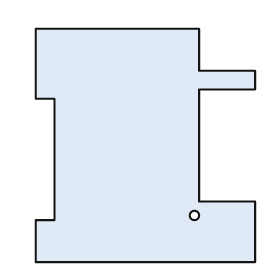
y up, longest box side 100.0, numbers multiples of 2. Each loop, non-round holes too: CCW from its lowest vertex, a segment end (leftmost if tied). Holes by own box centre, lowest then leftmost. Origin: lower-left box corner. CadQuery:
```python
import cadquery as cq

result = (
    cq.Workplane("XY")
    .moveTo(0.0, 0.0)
    .lineTo(94.0, 0.0)
    .lineTo(94.0, 26.0)
    .lineTo(70.0, 26.0)
    .lineTo(70.0, 74.0)
    .lineTo(94.0, 74.0)
    .lineTo(94.0, 82.0)
    .lineTo(70.0, 82.0)
    .lineTo(70.0, 100.0)
    .lineTo(0.0, 100.0)
    .lineTo(0.0, 70.0)
    .lineTo(8.0, 70.0)
    .lineTo(8.0, 18.0)
    .lineTo(0.0, 18.0)
    .close()
    .moveTo(68.0, 20.0)
    .circle(2.0)
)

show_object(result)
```